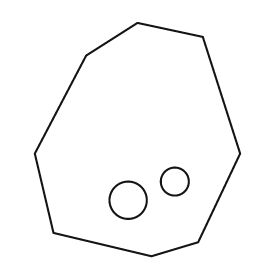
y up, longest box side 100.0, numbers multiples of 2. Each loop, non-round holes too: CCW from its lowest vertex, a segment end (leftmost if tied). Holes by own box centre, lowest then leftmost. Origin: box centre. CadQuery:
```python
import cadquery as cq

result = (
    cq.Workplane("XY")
    .moveTo(6.0, -50.0)
    .lineTo(26.0, -44.0)
    .lineTo(44.0, -6.0)
    .lineTo(28.0, 44.0)
    .lineTo(0.0, 50.0)
    .lineTo(-22.0, 36.0)
    .lineTo(-44.0, -6.0)
    .lineTo(-36.0, -40.0)
    .close()
    .moveTo(-4.0, -26.0)
    .circle(8.0)
    .moveTo(16.0, -18.0)
    .circle(6.0)
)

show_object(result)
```